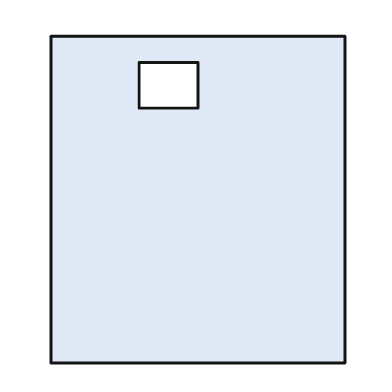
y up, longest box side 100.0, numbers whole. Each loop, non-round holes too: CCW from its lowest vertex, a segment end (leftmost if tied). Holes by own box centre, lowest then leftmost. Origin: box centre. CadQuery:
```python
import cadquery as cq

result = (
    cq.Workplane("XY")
    .moveTo(-45.0, -50.0)
    .lineTo(45.0, -50.0)
    .lineTo(45.0, 50.0)
    .lineTo(-45.0, 50.0)
    .close()
    .moveTo(-18.0, 28.0)
    .lineTo(0.0, 28.0)
    .lineTo(0.0, 42.0)
    .lineTo(-18.0, 42.0)
    .close()
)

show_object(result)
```